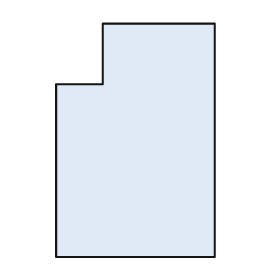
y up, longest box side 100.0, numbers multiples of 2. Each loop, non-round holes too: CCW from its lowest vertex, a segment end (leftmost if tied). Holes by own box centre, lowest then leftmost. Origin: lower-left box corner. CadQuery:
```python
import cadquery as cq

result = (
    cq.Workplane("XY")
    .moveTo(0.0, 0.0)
    .lineTo(68.0, 0.0)
    .lineTo(68.0, 100.0)
    .lineTo(20.0, 100.0)
    .lineTo(20.0, 74.0)
    .lineTo(0.0, 74.0)
    .close()
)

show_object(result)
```